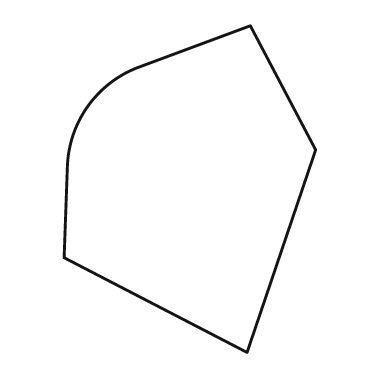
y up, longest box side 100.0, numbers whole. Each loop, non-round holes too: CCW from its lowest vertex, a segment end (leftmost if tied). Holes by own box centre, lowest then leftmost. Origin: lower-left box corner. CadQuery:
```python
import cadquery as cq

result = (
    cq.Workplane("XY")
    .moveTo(56.0, 0.0)
    .lineTo(77.0, 62.0)
    .lineTo(57.0, 100.0)
    .lineTo(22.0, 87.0)
    .threePointArc((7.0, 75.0), (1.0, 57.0))
    .lineTo(0.0, 29.0)
    .close()
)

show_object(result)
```